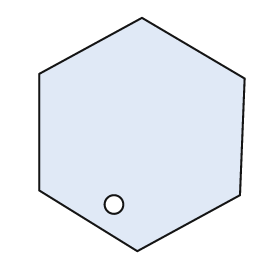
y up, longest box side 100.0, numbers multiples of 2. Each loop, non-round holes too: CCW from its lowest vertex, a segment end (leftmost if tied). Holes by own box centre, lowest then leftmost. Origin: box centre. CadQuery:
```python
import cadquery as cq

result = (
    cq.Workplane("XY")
    .moveTo(-2.0, -50.0)
    .lineTo(42.0, -26.0)
    .lineTo(44.0, 24.0)
    .lineTo(0.0, 50.0)
    .lineTo(-44.0, 26.0)
    .lineTo(-44.0, -24.0)
    .close()
    .moveTo(-12.0, -30.0)
    .circle(4.0)
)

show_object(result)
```